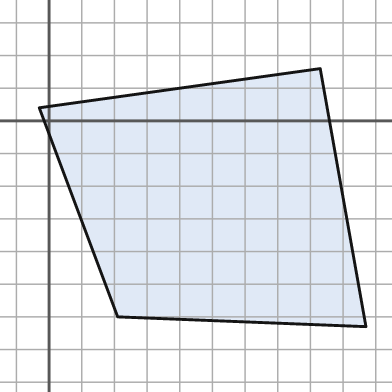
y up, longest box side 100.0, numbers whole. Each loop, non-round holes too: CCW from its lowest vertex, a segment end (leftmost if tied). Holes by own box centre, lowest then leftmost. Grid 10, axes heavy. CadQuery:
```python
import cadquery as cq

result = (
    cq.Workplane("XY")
    .moveTo(97.0, -63.0)
    .lineTo(83.0, 16.0)
    .lineTo(-3.0, 4.0)
    .lineTo(21.0, -60.0)
    .close()
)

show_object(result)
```